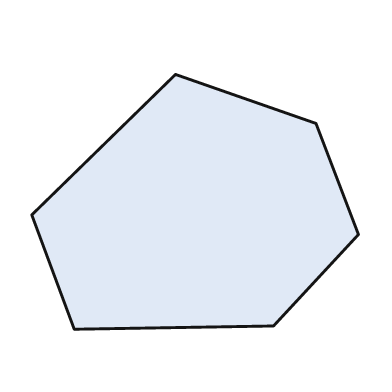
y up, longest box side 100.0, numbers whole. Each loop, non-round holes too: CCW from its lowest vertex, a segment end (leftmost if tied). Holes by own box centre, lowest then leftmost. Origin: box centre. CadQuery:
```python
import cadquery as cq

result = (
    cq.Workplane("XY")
    .moveTo(-37.0, -39.0)
    .lineTo(24.0, -38.0)
    .lineTo(50.0, -10.0)
    .lineTo(37.0, 24.0)
    .lineTo(-6.0, 39.0)
    .lineTo(-50.0, -4.0)
    .close()
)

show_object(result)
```